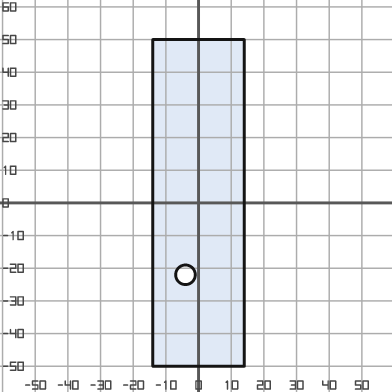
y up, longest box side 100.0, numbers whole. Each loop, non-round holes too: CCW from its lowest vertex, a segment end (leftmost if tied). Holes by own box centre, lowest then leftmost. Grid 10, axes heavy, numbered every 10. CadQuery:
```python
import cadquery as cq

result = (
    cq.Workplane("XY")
    .moveTo(-14.0, -50.0)
    .lineTo(14.0, -50.0)
    .lineTo(14.0, 50.0)
    .lineTo(-14.0, 50.0)
    .close()
    .moveTo(-4.0, -22.0)
    .circle(3.0)
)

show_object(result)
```